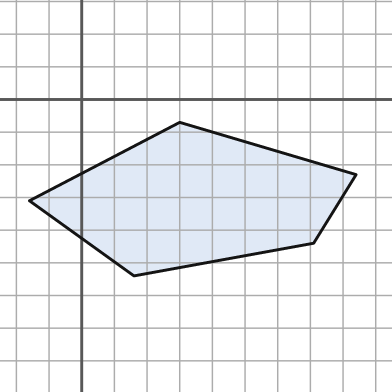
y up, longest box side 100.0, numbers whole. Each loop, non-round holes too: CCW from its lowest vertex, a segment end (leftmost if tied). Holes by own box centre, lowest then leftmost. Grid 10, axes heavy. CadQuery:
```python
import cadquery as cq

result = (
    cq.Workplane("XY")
    .moveTo(16.0, -54.0)
    .lineTo(71.0, -44.0)
    .lineTo(84.0, -23.0)
    .lineTo(30.0, -7.0)
    .lineTo(-16.0, -31.0)
    .close()
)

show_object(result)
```